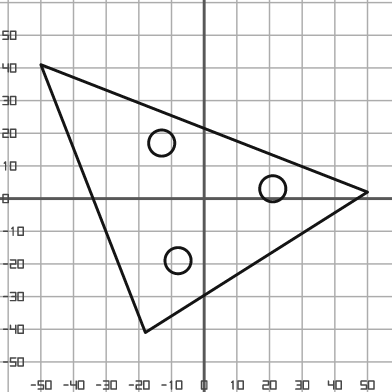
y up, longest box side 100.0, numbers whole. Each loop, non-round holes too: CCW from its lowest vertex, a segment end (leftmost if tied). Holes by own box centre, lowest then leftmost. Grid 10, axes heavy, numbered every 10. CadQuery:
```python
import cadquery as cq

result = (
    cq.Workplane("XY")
    .moveTo(-18.0, -41.0)
    .lineTo(50.0, 2.0)
    .lineTo(-50.0, 41.0)
    .close()
    .moveTo(-8.0, -19.0)
    .circle(4.0)
    .moveTo(21.0, 3.0)
    .circle(4.0)
    .moveTo(-13.0, 17.0)
    .circle(4.0)
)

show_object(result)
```